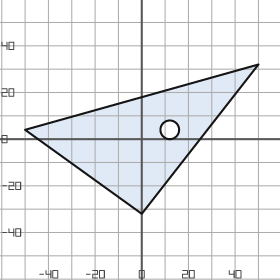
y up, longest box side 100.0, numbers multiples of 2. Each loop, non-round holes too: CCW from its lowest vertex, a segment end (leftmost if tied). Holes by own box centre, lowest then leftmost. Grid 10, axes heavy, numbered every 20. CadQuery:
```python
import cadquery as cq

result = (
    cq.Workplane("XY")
    .moveTo(0.0, -32.0)
    .lineTo(50.0, 32.0)
    .lineTo(-50.0, 4.0)
    .close()
    .moveTo(12.0, 4.0)
    .circle(4.0)
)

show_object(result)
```